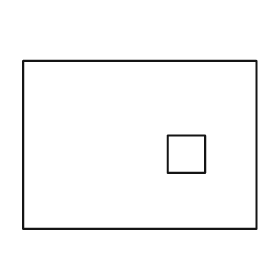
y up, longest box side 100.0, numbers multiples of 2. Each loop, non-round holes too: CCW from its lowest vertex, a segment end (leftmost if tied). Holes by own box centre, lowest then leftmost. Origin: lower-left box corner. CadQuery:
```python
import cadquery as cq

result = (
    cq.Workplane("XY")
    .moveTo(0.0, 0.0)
    .lineTo(100.0, 0.0)
    .lineTo(100.0, 72.0)
    .lineTo(0.0, 72.0)
    .close()
    .moveTo(62.0, 24.0)
    .lineTo(78.0, 24.0)
    .lineTo(78.0, 40.0)
    .lineTo(62.0, 40.0)
    .close()
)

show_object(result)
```